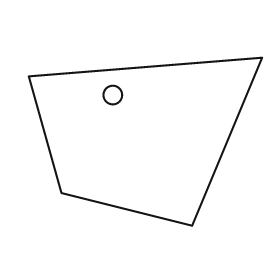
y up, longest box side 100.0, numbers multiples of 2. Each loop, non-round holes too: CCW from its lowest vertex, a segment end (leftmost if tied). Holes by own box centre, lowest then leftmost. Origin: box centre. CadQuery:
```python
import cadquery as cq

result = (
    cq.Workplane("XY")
    .moveTo(20.0, -36.0)
    .lineTo(50.0, 36.0)
    .lineTo(-50.0, 28.0)
    .lineTo(-36.0, -22.0)
    .close()
    .moveTo(-14.0, 20.0)
    .circle(4.0)
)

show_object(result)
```